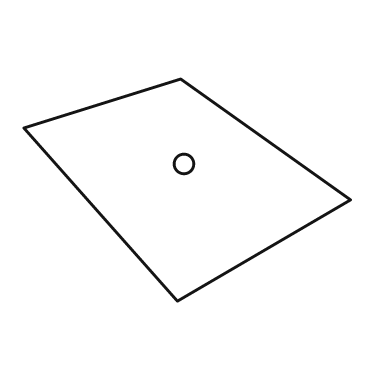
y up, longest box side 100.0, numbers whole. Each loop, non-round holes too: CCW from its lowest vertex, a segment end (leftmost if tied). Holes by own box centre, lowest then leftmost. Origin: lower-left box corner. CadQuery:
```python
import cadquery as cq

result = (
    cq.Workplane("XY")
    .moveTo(47.0, 0.0)
    .lineTo(100.0, 31.0)
    .lineTo(48.0, 68.0)
    .lineTo(0.0, 53.0)
    .close()
    .moveTo(49.0, 42.0)
    .circle(3.0)
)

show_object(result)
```